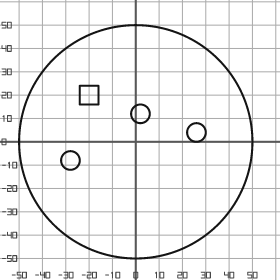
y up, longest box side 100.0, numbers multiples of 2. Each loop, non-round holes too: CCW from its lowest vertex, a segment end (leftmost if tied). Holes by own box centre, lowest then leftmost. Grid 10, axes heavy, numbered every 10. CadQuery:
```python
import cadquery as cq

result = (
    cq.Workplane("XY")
    .moveTo(0.0, 0.0)
    .circle(50.0)
    .moveTo(-28.0, -8.0)
    .circle(4.0)
    .moveTo(26.0, 4.0)
    .circle(4.0)
    .moveTo(2.0, 12.0)
    .circle(4.0)
    .moveTo(-24.0, 16.0)
    .lineTo(-16.0, 16.0)
    .lineTo(-16.0, 24.0)
    .lineTo(-24.0, 24.0)
    .close()
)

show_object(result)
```